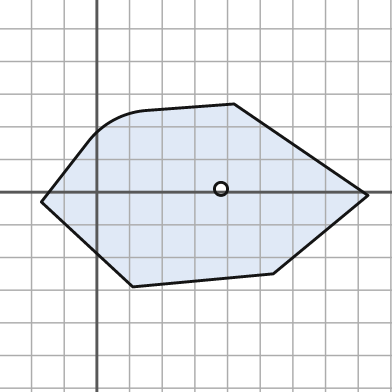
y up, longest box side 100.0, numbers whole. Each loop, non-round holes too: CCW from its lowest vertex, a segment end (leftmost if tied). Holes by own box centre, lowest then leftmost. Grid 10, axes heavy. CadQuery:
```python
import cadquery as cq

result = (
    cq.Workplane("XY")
    .moveTo(11.0, -29.0)
    .lineTo(54.0, -25.0)
    .lineTo(83.0, -1.0)
    .lineTo(42.0, 27.0)
    .lineTo(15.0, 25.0)
    .threePointArc((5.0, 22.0), (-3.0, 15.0))
    .lineTo(-17.0, -3.0)
    .close()
    .moveTo(38.0, 1.0)
    .circle(2.0)
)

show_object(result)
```